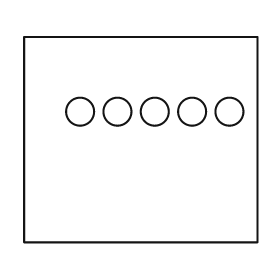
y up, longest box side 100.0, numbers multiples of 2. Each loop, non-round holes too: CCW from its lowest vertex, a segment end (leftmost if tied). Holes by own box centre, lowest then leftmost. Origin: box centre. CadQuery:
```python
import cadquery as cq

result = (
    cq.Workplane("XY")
    .moveTo(-50.0, -44.0)
    .lineTo(50.0, -44.0)
    .lineTo(50.0, 44.0)
    .lineTo(-50.0, 44.0)
    .close()
    .moveTo(-26.0, 12.0)
    .circle(6.0)
    .moveTo(-10.0, 12.0)
    .circle(6.0)
    .moveTo(6.0, 12.0)
    .circle(6.0)
    .moveTo(22.0, 12.0)
    .circle(6.0)
    .moveTo(38.0, 12.0)
    .circle(6.0)
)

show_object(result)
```